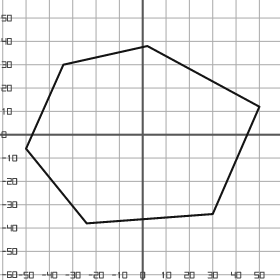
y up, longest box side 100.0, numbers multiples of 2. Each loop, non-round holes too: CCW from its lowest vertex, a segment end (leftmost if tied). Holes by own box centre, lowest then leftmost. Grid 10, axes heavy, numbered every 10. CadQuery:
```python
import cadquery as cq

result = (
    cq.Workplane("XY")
    .moveTo(-24.0, -38.0)
    .lineTo(30.0, -34.0)
    .lineTo(50.0, 12.0)
    .lineTo(2.0, 38.0)
    .lineTo(-34.0, 30.0)
    .lineTo(-50.0, -6.0)
    .close()
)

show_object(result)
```